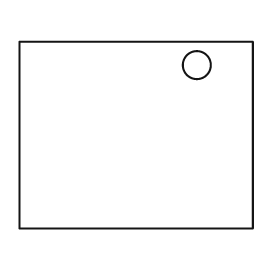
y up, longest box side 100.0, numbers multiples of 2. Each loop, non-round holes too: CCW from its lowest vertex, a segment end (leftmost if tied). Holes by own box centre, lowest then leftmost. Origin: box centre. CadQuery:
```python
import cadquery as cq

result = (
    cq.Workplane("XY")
    .moveTo(-50.0, -40.0)
    .lineTo(50.0, -40.0)
    .lineTo(50.0, 40.0)
    .lineTo(-50.0, 40.0)
    .close()
    .moveTo(26.0, 30.0)
    .circle(6.0)
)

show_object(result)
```